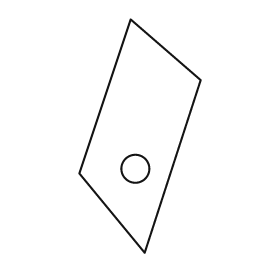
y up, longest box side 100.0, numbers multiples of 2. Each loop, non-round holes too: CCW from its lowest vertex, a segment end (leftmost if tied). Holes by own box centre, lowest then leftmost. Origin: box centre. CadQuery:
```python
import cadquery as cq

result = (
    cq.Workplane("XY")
    .moveTo(2.0, -50.0)
    .lineTo(26.0, 24.0)
    .lineTo(-4.0, 50.0)
    .lineTo(-26.0, -16.0)
    .close()
    .moveTo(-2.0, -14.0)
    .circle(6.0)
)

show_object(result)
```